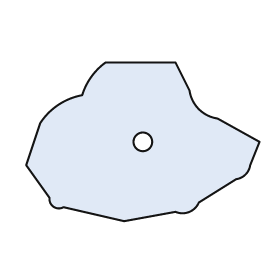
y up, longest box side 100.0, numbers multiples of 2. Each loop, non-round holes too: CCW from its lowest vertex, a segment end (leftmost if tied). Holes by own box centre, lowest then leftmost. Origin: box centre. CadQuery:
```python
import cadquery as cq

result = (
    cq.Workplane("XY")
    .moveTo(-8.0, -34.0)
    .lineTo(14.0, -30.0)
    .threePointArc((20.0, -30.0), (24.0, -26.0))
    .lineTo(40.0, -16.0)
    .threePointArc((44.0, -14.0), (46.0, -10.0))
    .lineTo(50.0, 0.0)
    .lineTo(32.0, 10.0)
    .threePointArc((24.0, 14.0), (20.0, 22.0))
    .lineTo(14.0, 34.0)
    .lineTo(-16.0, 34.0)
    .threePointArc((-22.0, 28.0), (-26.0, 20.0))
    .threePointArc((-36.0, 16.0), (-44.0, 8.0))
    .lineTo(-50.0, -10.0)
    .lineTo(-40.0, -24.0)
    .threePointArc((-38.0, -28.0), (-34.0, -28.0))
    .close()
    .moveTo(0.0, 0.0)
    .circle(4.0)
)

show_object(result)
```